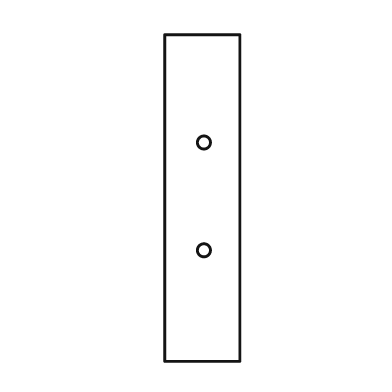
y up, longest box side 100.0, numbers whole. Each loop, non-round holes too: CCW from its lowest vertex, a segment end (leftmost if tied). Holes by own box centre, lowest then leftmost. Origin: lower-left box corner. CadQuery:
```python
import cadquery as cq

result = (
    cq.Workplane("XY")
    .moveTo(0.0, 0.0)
    .lineTo(23.0, 0.0)
    .lineTo(23.0, 100.0)
    .lineTo(0.0, 100.0)
    .close()
    .moveTo(12.0, 34.0)
    .circle(2.0)
    .moveTo(12.0, 67.0)
    .circle(2.0)
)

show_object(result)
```